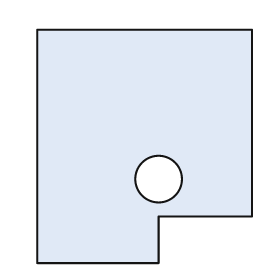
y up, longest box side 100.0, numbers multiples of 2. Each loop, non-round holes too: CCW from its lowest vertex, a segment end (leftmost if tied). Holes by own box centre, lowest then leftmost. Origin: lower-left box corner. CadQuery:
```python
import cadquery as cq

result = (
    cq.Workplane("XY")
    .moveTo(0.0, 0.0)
    .lineTo(52.0, 0.0)
    .lineTo(52.0, 20.0)
    .lineTo(92.0, 20.0)
    .lineTo(92.0, 100.0)
    .lineTo(0.0, 100.0)
    .close()
    .moveTo(52.0, 36.0)
    .circle(10.0)
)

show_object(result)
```